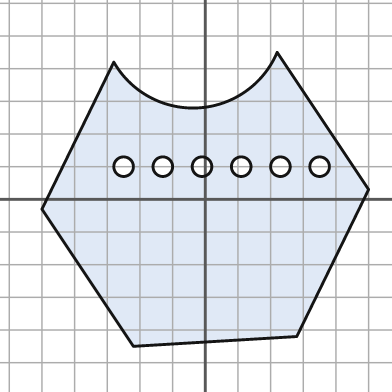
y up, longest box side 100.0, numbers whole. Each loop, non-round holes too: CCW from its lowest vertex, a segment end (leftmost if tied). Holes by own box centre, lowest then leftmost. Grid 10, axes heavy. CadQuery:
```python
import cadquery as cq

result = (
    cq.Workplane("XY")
    .moveTo(-22.0, -45.0)
    .lineTo(28.0, -42.0)
    .lineTo(50.0, 3.0)
    .lineTo(22.0, 45.0)
    .threePointArc((-2.0, 28.0), (-28.0, 42.0))
    .lineTo(-50.0, -3.0)
    .close()
    .moveTo(-25.0, 10.0)
    .circle(3.0)
    .moveTo(-13.0, 10.0)
    .circle(3.0)
    .moveTo(-1.0, 10.0)
    .circle(3.0)
    .moveTo(11.0, 10.0)
    .circle(3.0)
    .moveTo(23.0, 10.0)
    .circle(3.0)
    .moveTo(35.0, 10.0)
    .circle(3.0)
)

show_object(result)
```